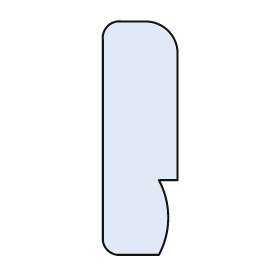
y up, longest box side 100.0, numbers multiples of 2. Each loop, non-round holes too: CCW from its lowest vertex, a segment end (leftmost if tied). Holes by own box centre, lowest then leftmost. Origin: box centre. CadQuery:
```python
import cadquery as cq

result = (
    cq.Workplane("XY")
    .moveTo(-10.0, -50.0)
    .lineTo(8.0, -50.0)
    .threePointArc((12.0, -34.0), (8.0, -18.0))
    .lineTo(16.0, -18.0)
    .lineTo(16.0, 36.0)
    .threePointArc((12.0, 46.0), (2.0, 50.0))
    .lineTo(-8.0, 50.0)
    .threePointArc((-14.0, 48.0), (-16.0, 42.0))
    .lineTo(-16.0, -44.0)
    .threePointArc((-14.0, -48.0), (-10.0, -50.0))
    .close()
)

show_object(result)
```